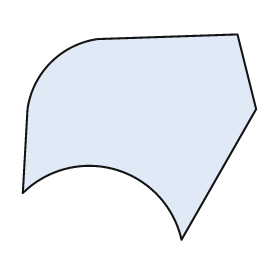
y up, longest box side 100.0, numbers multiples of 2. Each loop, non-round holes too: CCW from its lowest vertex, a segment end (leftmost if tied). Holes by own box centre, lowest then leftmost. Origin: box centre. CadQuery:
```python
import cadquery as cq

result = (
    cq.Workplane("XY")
    .moveTo(18.0, -44.0)
    .lineTo(50.0, 12.0)
    .lineTo(42.0, 44.0)
    .lineTo(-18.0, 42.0)
    .threePointArc((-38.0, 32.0), (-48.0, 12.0))
    .lineTo(-50.0, -24.0)
    .threePointArc((-10.0, -14.0), (18.0, -44.0))
    .close()
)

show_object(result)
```